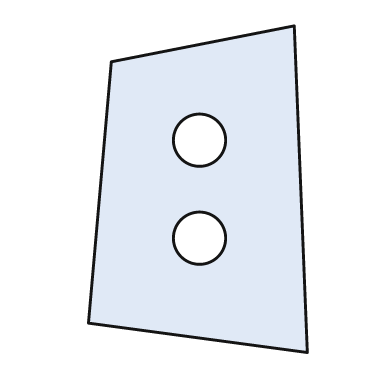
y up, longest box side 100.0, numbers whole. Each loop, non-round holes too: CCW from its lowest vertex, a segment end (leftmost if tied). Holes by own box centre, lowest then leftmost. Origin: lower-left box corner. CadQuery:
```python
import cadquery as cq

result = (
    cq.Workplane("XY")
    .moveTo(67.0, 0.0)
    .lineTo(63.0, 100.0)
    .lineTo(7.0, 89.0)
    .lineTo(0.0, 9.0)
    .close()
    .moveTo(34.0, 35.0)
    .circle(8.0)
    .moveTo(34.0, 65.0)
    .circle(8.0)
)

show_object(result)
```